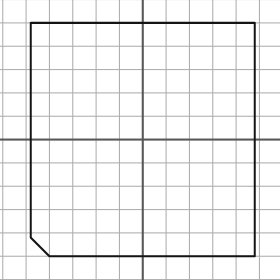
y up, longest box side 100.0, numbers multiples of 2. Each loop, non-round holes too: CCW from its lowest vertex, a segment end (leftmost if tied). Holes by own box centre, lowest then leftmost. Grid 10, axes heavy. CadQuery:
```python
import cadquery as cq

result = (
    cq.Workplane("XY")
    .moveTo(-40.0, -50.0)
    .lineTo(48.0, -50.0)
    .lineTo(48.0, 50.0)
    .lineTo(-48.0, 50.0)
    .lineTo(-48.0, -42.0)
    .close()
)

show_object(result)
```